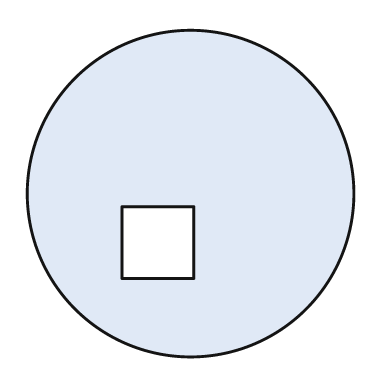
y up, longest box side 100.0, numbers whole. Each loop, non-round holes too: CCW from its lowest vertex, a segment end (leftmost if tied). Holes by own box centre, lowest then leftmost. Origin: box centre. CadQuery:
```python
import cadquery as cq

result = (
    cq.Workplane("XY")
    .moveTo(0.0, 0.0)
    .circle(50.0)
    .moveTo(-21.0, -26.0)
    .lineTo(1.0, -26.0)
    .lineTo(1.0, -4.0)
    .lineTo(-21.0, -4.0)
    .close()
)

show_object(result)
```